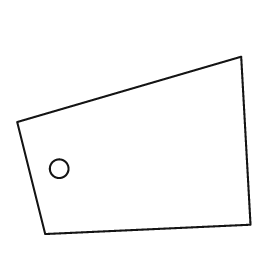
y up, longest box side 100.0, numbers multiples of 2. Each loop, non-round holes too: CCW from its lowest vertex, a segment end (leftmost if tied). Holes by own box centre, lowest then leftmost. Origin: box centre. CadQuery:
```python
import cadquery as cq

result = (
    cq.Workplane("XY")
    .moveTo(-38.0, -38.0)
    .lineTo(50.0, -34.0)
    .lineTo(46.0, 38.0)
    .lineTo(-50.0, 10.0)
    .close()
    .moveTo(-32.0, -10.0)
    .circle(4.0)
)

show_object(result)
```